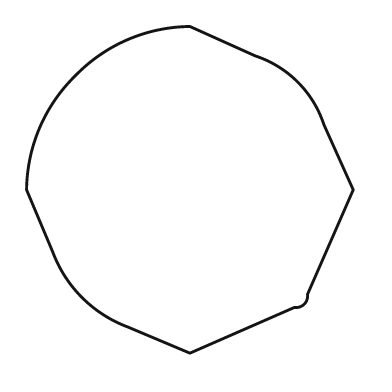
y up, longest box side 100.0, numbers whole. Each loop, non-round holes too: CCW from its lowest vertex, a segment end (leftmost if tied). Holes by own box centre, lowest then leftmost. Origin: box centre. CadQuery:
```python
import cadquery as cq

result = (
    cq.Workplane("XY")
    .moveTo(0.0, -50.0)
    .lineTo(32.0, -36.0)
    .threePointArc((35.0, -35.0), (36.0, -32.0))
    .lineTo(50.0, 0.0)
    .lineTo(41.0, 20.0)
    .threePointArc((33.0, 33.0), (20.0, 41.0))
    .lineTo(0.0, 50.0)
    .threePointArc((-19.0, 46.0), (-35.0, 35.0))
    .threePointArc((-46.0, 19.0), (-50.0, 0.0))
    .lineTo(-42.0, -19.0)
    .threePointArc((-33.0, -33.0), (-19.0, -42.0))
    .close()
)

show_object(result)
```